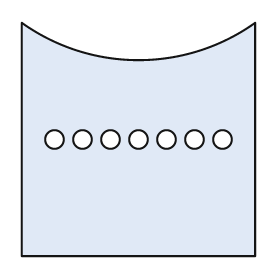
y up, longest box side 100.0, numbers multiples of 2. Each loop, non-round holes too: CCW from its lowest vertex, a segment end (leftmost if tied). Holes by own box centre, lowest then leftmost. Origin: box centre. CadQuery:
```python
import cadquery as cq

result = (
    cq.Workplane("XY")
    .moveTo(-50.0, -50.0)
    .lineTo(50.0, -50.0)
    .lineTo(50.0, 50.0)
    .threePointArc((0.0, 34.0), (-50.0, 50.0))
    .close()
    .moveTo(-36.0, 0.0)
    .circle(4.0)
    .moveTo(-24.0, 0.0)
    .circle(4.0)
    .moveTo(-12.0, 0.0)
    .circle(4.0)
    .moveTo(0.0, 0.0)
    .circle(4.0)
    .moveTo(12.0, 0.0)
    .circle(4.0)
    .moveTo(24.0, 0.0)
    .circle(4.0)
    .moveTo(36.0, 0.0)
    .circle(4.0)
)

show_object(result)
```